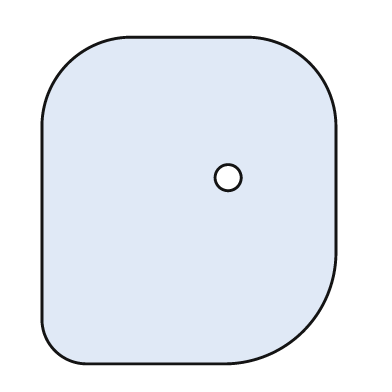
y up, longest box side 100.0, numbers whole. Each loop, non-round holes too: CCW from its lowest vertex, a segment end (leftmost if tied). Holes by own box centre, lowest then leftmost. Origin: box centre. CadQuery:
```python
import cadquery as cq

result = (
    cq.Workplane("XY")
    .moveTo(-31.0, -50.0)
    .lineTo(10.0, -50.0)
    .threePointArc((35.0, -40.0), (45.0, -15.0))
    .lineTo(45.0, 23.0)
    .threePointArc((37.0, 42.0), (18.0, 50.0))
    .lineTo(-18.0, 50.0)
    .threePointArc((-37.0, 42.0), (-45.0, 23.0))
    .lineTo(-45.0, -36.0)
    .threePointArc((-41.0, -46.0), (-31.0, -50.0))
    .close()
    .moveTo(12.0, 7.0)
    .circle(4.0)
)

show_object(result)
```